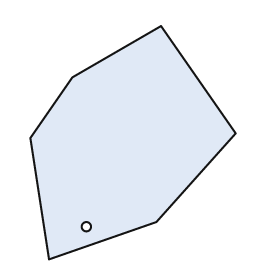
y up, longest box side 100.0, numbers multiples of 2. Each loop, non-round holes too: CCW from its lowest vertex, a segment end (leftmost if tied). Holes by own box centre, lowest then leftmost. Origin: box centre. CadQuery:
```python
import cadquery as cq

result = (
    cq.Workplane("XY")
    .moveTo(-36.0, -50.0)
    .lineTo(10.0, -34.0)
    .lineTo(44.0, 4.0)
    .lineTo(12.0, 50.0)
    .lineTo(-26.0, 28.0)
    .lineTo(-44.0, 2.0)
    .close()
    .moveTo(-20.0, -36.0)
    .circle(2.0)
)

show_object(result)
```